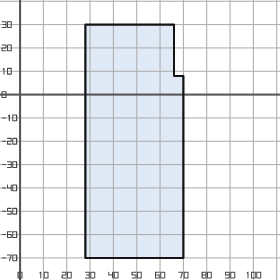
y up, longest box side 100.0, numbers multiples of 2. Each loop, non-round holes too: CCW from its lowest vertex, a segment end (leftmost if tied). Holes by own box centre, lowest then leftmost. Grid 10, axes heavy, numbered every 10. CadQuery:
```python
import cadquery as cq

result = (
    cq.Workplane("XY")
    .moveTo(28.0, -70.0)
    .lineTo(70.0, -70.0)
    .lineTo(70.0, 8.0)
    .lineTo(66.0, 8.0)
    .lineTo(66.0, 30.0)
    .lineTo(28.0, 30.0)
    .close()
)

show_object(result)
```